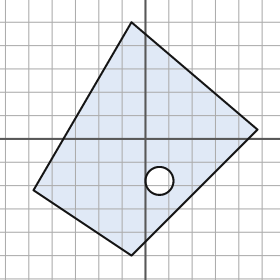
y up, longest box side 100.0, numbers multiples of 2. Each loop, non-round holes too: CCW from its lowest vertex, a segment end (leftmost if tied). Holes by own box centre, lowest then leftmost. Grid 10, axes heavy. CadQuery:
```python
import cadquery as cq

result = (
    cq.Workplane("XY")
    .moveTo(-6.0, -50.0)
    .lineTo(48.0, 4.0)
    .lineTo(-6.0, 50.0)
    .lineTo(-48.0, -22.0)
    .close()
    .moveTo(6.0, -18.0)
    .circle(6.0)
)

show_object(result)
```